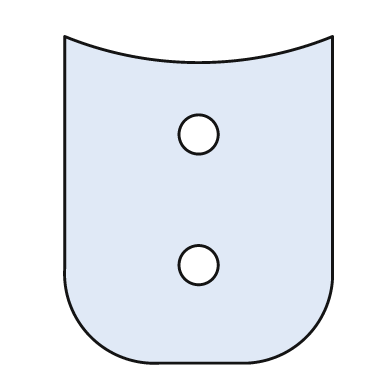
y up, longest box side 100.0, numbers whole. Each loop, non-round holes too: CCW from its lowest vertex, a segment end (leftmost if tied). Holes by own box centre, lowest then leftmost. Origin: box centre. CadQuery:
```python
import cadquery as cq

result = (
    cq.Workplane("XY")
    .moveTo(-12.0, -50.0)
    .lineTo(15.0, -50.0)
    .threePointArc((33.0, -42.0), (41.0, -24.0))
    .lineTo(41.0, 50.0)
    .threePointArc((0.0, 42.0), (-41.0, 50.0))
    .lineTo(-41.0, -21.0)
    .threePointArc((-33.0, -42.0), (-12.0, -50.0))
    .close()
    .moveTo(0.0, -20.0)
    .circle(6.0)
    .moveTo(0.0, 20.0)
    .circle(6.0)
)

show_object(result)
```